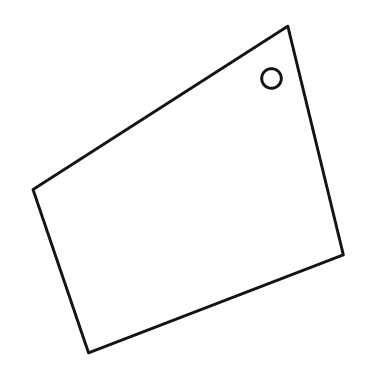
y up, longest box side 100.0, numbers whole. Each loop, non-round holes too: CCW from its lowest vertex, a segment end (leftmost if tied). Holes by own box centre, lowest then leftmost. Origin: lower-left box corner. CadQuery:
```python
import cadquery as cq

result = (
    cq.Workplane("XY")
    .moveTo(17.0, 0.0)
    .lineTo(95.0, 30.0)
    .lineTo(78.0, 100.0)
    .lineTo(0.0, 50.0)
    .close()
    .moveTo(73.0, 84.0)
    .circle(3.0)
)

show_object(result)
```